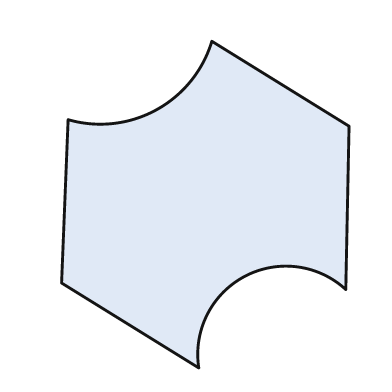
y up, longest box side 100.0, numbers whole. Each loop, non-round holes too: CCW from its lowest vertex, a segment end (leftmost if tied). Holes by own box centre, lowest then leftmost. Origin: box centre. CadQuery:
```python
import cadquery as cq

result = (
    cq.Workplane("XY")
    .moveTo(-2.0, -50.0)
    .threePointArc((12.0, -22.0), (43.0, -26.0))
    .lineTo(44.0, 24.0)
    .lineTo(2.0, 50.0)
    .threePointArc((-15.0, 29.0), (-42.0, 26.0))
    .lineTo(-44.0, -24.0)
    .close()
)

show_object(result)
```